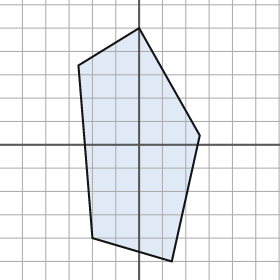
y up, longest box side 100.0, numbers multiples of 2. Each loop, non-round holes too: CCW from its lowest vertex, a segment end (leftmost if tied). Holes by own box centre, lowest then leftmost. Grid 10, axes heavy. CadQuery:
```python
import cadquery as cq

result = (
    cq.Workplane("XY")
    .moveTo(14.0, -50.0)
    .lineTo(26.0, 4.0)
    .lineTo(0.0, 50.0)
    .lineTo(-26.0, 34.0)
    .lineTo(-20.0, -40.0)
    .close()
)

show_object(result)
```